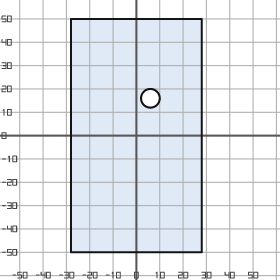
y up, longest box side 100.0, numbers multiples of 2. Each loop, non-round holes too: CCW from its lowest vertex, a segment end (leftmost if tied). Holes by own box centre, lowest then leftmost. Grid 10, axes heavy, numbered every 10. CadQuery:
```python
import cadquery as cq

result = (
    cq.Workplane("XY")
    .moveTo(-28.0, -50.0)
    .lineTo(28.0, -50.0)
    .lineTo(28.0, 50.0)
    .lineTo(-28.0, 50.0)
    .close()
    .moveTo(6.0, 16.0)
    .circle(4.0)
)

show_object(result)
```